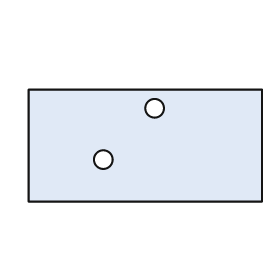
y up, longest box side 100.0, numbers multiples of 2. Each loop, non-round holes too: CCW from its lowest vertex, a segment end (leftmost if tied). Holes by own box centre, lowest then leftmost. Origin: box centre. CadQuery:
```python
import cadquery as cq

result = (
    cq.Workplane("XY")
    .moveTo(-50.0, -24.0)
    .lineTo(50.0, -24.0)
    .lineTo(50.0, 24.0)
    .lineTo(-50.0, 24.0)
    .close()
    .moveTo(-18.0, -6.0)
    .circle(4.0)
    .moveTo(4.0, 16.0)
    .circle(4.0)
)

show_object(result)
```